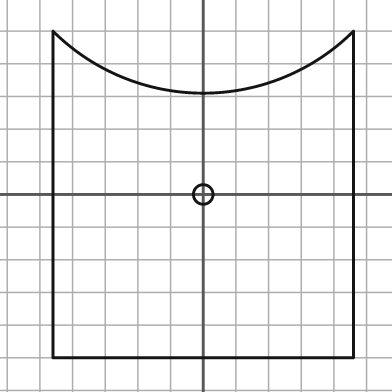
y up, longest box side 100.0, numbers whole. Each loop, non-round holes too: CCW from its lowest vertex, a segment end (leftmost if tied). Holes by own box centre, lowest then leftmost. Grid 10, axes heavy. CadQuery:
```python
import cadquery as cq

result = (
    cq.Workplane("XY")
    .moveTo(-46.0, -50.0)
    .lineTo(46.0, -50.0)
    .lineTo(46.0, 50.0)
    .threePointArc((0.0, 31.0), (-46.0, 50.0))
    .close()
    .moveTo(0.0, 0.0)
    .circle(3.0)
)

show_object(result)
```